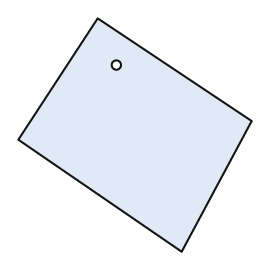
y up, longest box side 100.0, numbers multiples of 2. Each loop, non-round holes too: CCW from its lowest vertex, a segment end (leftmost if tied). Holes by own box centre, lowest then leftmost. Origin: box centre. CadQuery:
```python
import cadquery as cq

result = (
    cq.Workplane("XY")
    .moveTo(20.0, -50.0)
    .lineTo(50.0, 6.0)
    .lineTo(-16.0, 50.0)
    .lineTo(-50.0, -2.0)
    .close()
    .moveTo(-8.0, 30.0)
    .circle(2.0)
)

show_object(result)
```